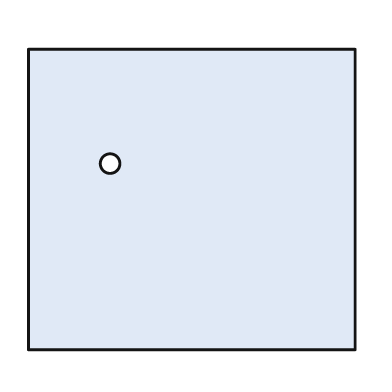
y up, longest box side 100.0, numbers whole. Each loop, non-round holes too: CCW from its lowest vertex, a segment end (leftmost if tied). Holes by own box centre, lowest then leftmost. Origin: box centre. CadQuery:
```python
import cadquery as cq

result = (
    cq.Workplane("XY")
    .moveTo(-50.0, -46.0)
    .lineTo(50.0, -46.0)
    .lineTo(50.0, 46.0)
    .lineTo(-50.0, 46.0)
    .close()
    .moveTo(-25.0, 11.0)
    .circle(3.0)
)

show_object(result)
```